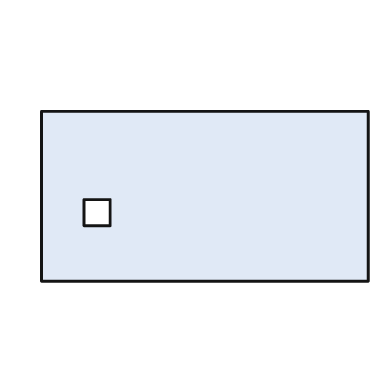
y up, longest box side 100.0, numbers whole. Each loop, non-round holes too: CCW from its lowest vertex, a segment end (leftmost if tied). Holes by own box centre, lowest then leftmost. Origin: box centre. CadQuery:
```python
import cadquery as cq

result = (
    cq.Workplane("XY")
    .moveTo(-50.0, -26.0)
    .lineTo(50.0, -26.0)
    .lineTo(50.0, 26.0)
    .lineTo(-50.0, 26.0)
    .close()
    .moveTo(-37.0, -9.0)
    .lineTo(-29.0, -9.0)
    .lineTo(-29.0, -1.0)
    .lineTo(-37.0, -1.0)
    .close()
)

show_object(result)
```